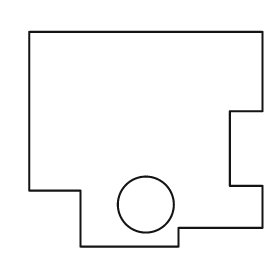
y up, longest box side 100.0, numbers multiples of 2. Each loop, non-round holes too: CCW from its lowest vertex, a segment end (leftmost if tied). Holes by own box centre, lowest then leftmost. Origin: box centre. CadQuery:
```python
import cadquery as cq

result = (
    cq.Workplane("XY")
    .moveTo(-28.0, -46.0)
    .lineTo(14.0, -46.0)
    .lineTo(14.0, -38.0)
    .lineTo(50.0, -38.0)
    .lineTo(50.0, -20.0)
    .lineTo(36.0, -20.0)
    .lineTo(36.0, 12.0)
    .lineTo(50.0, 12.0)
    .lineTo(50.0, 46.0)
    .lineTo(-50.0, 46.0)
    .lineTo(-50.0, -22.0)
    .lineTo(-28.0, -22.0)
    .close()
    .moveTo(0.0, -28.0)
    .circle(12.0)
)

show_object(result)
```